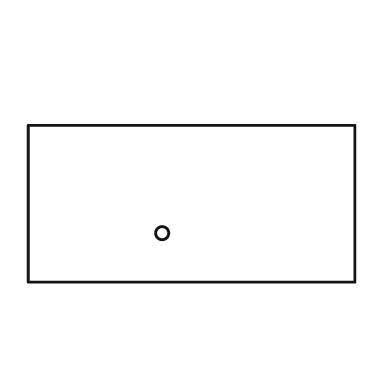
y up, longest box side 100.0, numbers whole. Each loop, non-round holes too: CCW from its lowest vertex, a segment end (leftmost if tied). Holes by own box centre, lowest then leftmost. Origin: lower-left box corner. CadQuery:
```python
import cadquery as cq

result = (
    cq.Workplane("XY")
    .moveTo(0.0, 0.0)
    .lineTo(100.0, 0.0)
    .lineTo(100.0, 48.0)
    .lineTo(0.0, 48.0)
    .close()
    .moveTo(41.0, 15.0)
    .circle(2.0)
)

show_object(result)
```